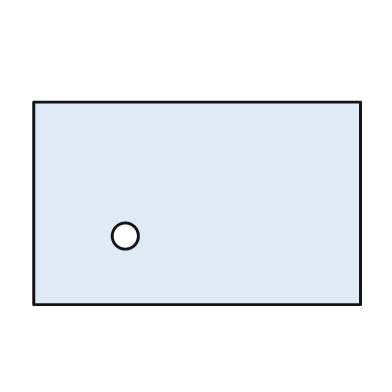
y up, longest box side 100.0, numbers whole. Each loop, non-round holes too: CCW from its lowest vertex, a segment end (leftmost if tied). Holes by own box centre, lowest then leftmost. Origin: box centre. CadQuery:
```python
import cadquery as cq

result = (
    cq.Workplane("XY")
    .moveTo(-50.0, -31.0)
    .lineTo(50.0, -31.0)
    .lineTo(50.0, 31.0)
    .lineTo(-50.0, 31.0)
    .close()
    .moveTo(-22.0, -10.0)
    .circle(4.0)
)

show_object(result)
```